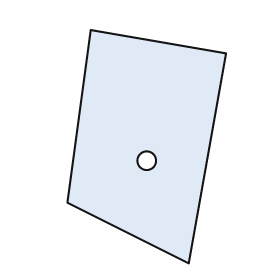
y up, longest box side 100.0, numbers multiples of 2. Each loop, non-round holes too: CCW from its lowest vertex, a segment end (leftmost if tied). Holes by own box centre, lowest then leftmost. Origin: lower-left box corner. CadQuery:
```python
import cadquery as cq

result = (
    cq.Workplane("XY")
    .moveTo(52.0, 0.0)
    .lineTo(68.0, 90.0)
    .lineTo(10.0, 100.0)
    .lineTo(0.0, 26.0)
    .close()
    .moveTo(34.0, 44.0)
    .circle(4.0)
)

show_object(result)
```